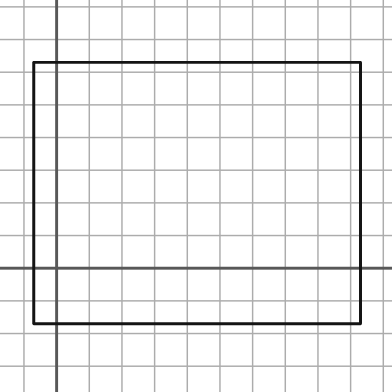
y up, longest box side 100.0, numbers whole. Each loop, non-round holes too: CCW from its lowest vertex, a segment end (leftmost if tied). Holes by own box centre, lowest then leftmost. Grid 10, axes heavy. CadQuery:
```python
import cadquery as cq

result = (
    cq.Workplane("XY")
    .moveTo(-7.0, -17.0)
    .lineTo(93.0, -17.0)
    .lineTo(93.0, 63.0)
    .lineTo(-7.0, 63.0)
    .close()
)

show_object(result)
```